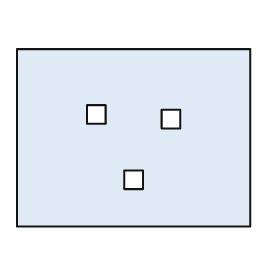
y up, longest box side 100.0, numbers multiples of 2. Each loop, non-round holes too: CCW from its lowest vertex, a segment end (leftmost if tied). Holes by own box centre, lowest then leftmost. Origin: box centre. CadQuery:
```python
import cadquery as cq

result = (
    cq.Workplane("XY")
    .moveTo(-50.0, -38.0)
    .lineTo(50.0, -38.0)
    .lineTo(50.0, 38.0)
    .lineTo(-50.0, 38.0)
    .close()
    .moveTo(-4.0, -22.0)
    .lineTo(4.0, -22.0)
    .lineTo(4.0, -14.0)
    .lineTo(-4.0, -14.0)
    .close()
    .moveTo(12.0, 4.0)
    .lineTo(20.0, 4.0)
    .lineTo(20.0, 12.0)
    .lineTo(12.0, 12.0)
    .close()
    .moveTo(-20.0, 6.0)
    .lineTo(-12.0, 6.0)
    .lineTo(-12.0, 14.0)
    .lineTo(-20.0, 14.0)
    .close()
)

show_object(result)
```